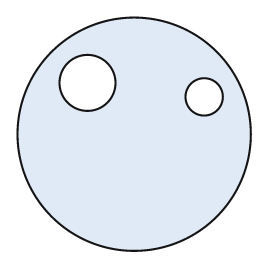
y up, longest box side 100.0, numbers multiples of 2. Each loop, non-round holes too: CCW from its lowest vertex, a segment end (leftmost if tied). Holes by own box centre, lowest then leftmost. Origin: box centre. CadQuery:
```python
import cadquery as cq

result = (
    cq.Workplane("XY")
    .moveTo(0.0, 0.0)
    .circle(50.0)
    .moveTo(30.0, 16.0)
    .circle(8.0)
    .moveTo(-20.0, 22.0)
    .circle(12.0)
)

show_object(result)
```